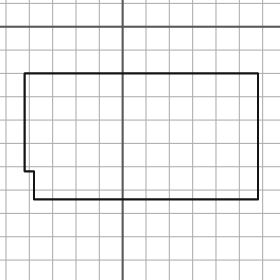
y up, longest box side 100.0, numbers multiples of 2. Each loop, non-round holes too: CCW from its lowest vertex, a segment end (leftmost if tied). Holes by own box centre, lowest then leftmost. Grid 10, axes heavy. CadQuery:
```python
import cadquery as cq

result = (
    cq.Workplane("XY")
    .moveTo(-38.0, -74.0)
    .lineTo(58.0, -74.0)
    .lineTo(58.0, -20.0)
    .lineTo(-42.0, -20.0)
    .lineTo(-42.0, -62.0)
    .lineTo(-38.0, -62.0)
    .close()
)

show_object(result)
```